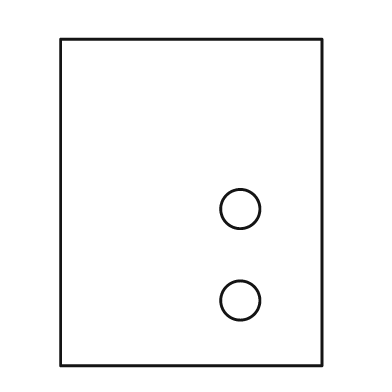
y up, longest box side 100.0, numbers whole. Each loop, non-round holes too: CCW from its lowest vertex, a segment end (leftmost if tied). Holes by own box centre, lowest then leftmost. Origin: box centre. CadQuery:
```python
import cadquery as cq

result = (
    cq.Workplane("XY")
    .moveTo(-40.0, -50.0)
    .lineTo(40.0, -50.0)
    .lineTo(40.0, 50.0)
    .lineTo(-40.0, 50.0)
    .close()
    .moveTo(15.0, -30.0)
    .circle(6.0)
    .moveTo(15.0, -2.0)
    .circle(6.0)
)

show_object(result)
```